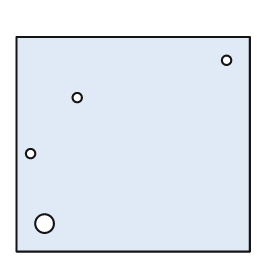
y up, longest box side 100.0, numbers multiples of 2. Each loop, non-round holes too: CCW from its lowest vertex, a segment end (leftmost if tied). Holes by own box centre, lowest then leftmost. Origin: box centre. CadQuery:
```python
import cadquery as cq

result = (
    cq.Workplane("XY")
    .moveTo(-50.0, -46.0)
    .lineTo(50.0, -46.0)
    .lineTo(50.0, 46.0)
    .lineTo(-50.0, 46.0)
    .close()
    .moveTo(-38.0, -34.0)
    .circle(4.0)
    .moveTo(-44.0, -4.0)
    .circle(2.0)
    .moveTo(-24.0, 20.0)
    .circle(2.0)
    .moveTo(40.0, 36.0)
    .circle(2.0)
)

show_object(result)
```